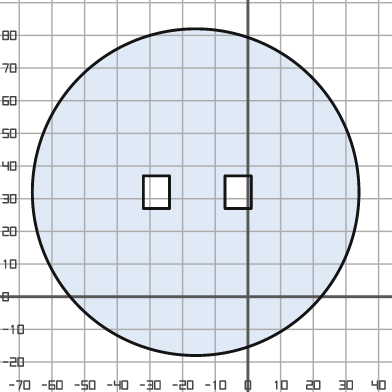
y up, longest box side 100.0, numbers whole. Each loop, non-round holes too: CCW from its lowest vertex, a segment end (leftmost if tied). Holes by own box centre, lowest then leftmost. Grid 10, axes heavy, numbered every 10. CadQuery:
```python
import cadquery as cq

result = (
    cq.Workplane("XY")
    .moveTo(-16.0, 32.0)
    .circle(50.0)
    .moveTo(-32.0, 27.0)
    .lineTo(-24.0, 27.0)
    .lineTo(-24.0, 37.0)
    .lineTo(-32.0, 37.0)
    .close()
    .moveTo(-7.0, 27.0)
    .lineTo(1.0, 27.0)
    .lineTo(1.0, 37.0)
    .lineTo(-7.0, 37.0)
    .close()
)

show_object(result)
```